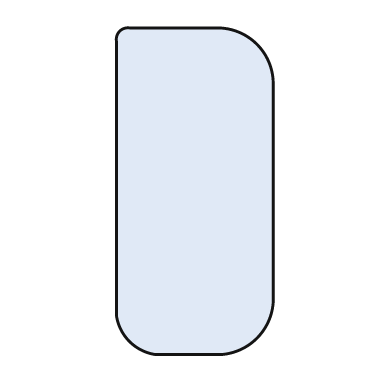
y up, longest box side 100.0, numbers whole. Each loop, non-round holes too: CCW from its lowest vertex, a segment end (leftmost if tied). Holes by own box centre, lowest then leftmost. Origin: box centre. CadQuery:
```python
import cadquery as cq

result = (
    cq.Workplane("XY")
    .moveTo(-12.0, -50.0)
    .lineTo(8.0, -50.0)
    .threePointArc((19.0, -45.0), (24.0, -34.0))
    .lineTo(24.0, 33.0)
    .threePointArc((19.0, 45.0), (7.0, 50.0))
    .lineTo(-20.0, 50.0)
    .threePointArc((-23.0, 49.0), (-24.0, 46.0))
    .lineTo(-24.0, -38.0)
    .threePointArc((-20.0, -46.0), (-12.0, -50.0))
    .close()
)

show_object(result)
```